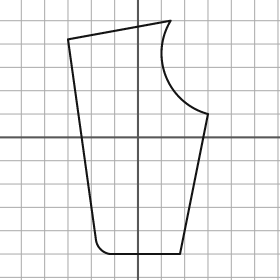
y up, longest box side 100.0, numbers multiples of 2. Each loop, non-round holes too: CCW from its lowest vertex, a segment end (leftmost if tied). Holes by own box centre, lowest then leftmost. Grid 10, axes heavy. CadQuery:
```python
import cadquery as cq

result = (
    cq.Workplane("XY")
    .moveTo(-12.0, -50.0)
    .lineTo(18.0, -50.0)
    .lineTo(30.0, 10.0)
    .threePointArc((12.0, 26.0), (14.0, 50.0))
    .lineTo(-30.0, 42.0)
    .lineTo(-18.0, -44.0)
    .threePointArc((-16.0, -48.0), (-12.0, -50.0))
    .close()
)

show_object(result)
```